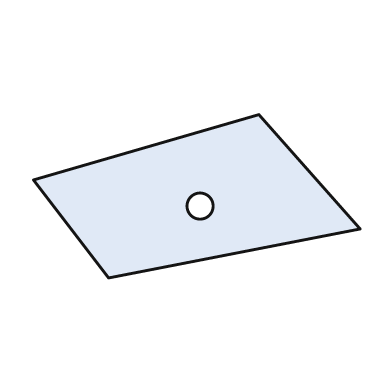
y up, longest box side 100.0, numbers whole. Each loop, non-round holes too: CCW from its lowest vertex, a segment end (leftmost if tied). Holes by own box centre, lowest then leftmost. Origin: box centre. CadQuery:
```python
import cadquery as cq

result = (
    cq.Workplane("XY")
    .moveTo(-27.0, -25.0)
    .lineTo(50.0, -10.0)
    .lineTo(19.0, 25.0)
    .lineTo(-50.0, 5.0)
    .close()
    .moveTo(1.0, -3.0)
    .circle(4.0)
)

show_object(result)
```